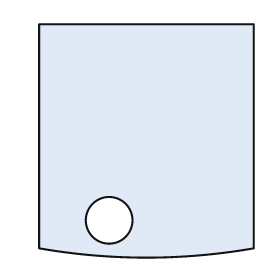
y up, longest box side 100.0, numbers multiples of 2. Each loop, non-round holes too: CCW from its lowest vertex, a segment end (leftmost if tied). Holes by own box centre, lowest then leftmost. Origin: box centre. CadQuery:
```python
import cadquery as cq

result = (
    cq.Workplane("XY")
    .moveTo(-46.0, -46.0)
    .threePointArc((0.0, -50.0), (46.0, -46.0))
    .lineTo(46.0, 50.0)
    .lineTo(-46.0, 50.0)
    .close()
    .moveTo(-16.0, -34.0)
    .circle(10.0)
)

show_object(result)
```